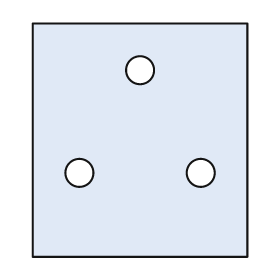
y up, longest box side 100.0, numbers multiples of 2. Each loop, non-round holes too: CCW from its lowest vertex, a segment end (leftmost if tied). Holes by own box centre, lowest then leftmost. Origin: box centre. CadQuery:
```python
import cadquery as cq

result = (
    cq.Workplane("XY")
    .moveTo(-46.0, -50.0)
    .lineTo(46.0, -50.0)
    .lineTo(46.0, 50.0)
    .lineTo(-46.0, 50.0)
    .close()
    .moveTo(-26.0, -14.0)
    .circle(6.0)
    .moveTo(26.0, -14.0)
    .circle(6.0)
    .moveTo(0.0, 30.0)
    .circle(6.0)
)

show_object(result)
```